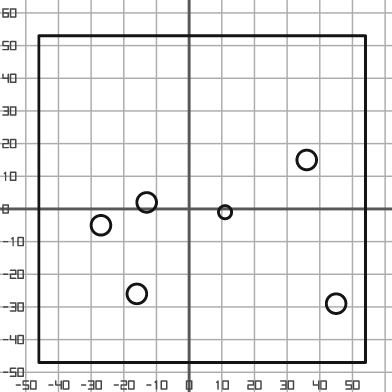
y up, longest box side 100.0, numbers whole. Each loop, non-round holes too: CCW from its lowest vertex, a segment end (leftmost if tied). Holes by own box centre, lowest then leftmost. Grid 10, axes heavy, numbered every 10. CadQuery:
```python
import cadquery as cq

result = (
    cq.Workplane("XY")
    .moveTo(-46.0, -47.0)
    .lineTo(54.0, -47.0)
    .lineTo(54.0, 53.0)
    .lineTo(-46.0, 53.0)
    .close()
    .moveTo(45.0, -29.0)
    .circle(3.0)
    .moveTo(-16.0, -26.0)
    .circle(3.0)
    .moveTo(-27.0, -5.0)
    .circle(3.0)
    .moveTo(11.0, -1.0)
    .circle(2.0)
    .moveTo(-13.0, 2.0)
    .circle(3.0)
    .moveTo(36.0, 15.0)
    .circle(3.0)
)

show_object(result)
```